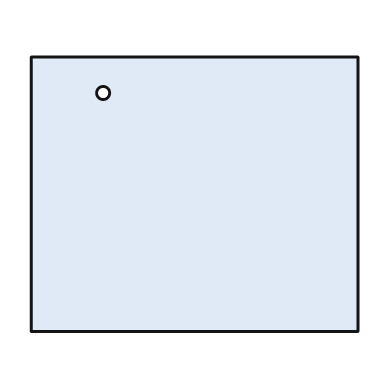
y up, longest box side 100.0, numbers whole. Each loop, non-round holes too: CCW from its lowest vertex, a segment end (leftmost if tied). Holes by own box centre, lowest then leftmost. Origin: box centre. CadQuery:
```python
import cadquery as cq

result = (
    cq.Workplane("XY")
    .moveTo(-50.0, -42.0)
    .lineTo(50.0, -42.0)
    .lineTo(50.0, 42.0)
    .lineTo(-50.0, 42.0)
    .close()
    .moveTo(-28.0, 31.0)
    .circle(2.0)
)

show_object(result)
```